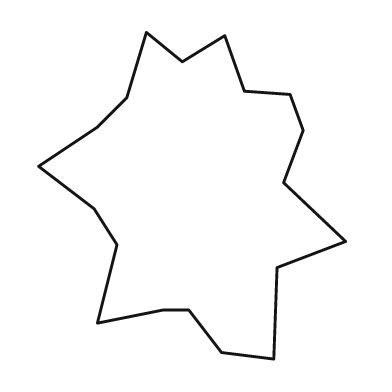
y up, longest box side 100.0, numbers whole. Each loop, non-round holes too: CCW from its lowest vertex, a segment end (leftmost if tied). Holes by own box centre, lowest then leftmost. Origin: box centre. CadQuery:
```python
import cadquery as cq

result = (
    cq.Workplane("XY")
    .moveTo(25.0, -50.0)
    .lineTo(26.0, -22.0)
    .lineTo(47.0, -14.0)
    .lineTo(28.0, 4.0)
    .lineTo(34.0, 20.0)
    .lineTo(30.0, 31.0)
    .lineTo(16.0, 32.0)
    .lineTo(10.0, 49.0)
    .lineTo(-3.0, 41.0)
    .lineTo(-14.0, 50.0)
    .lineTo(-20.0, 30.0)
    .lineTo(-29.0, 21.0)
    .lineTo(-47.0, 9.0)
    .lineTo(-30.0, -4.0)
    .lineTo(-23.0, -15.0)
    .lineTo(-29.0, -39.0)
    .lineTo(-9.0, -35.0)
    .lineTo(-1.0, -35.0)
    .lineTo(9.0, -48.0)
    .close()
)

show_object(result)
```